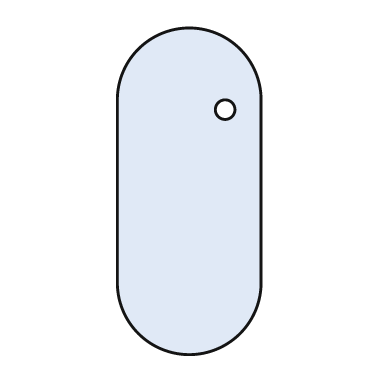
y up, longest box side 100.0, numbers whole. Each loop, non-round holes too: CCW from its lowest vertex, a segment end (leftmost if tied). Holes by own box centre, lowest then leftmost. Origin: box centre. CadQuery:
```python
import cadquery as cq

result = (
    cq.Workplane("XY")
    .moveTo(-22.0, -28.0)
    .threePointArc((0.0, -50.0), (22.0, -28.0))
    .lineTo(22.0, 28.0)
    .threePointArc((0.0, 50.0), (-22.0, 28.0))
    .close()
    .moveTo(11.0, 25.0)
    .circle(3.0)
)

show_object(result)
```